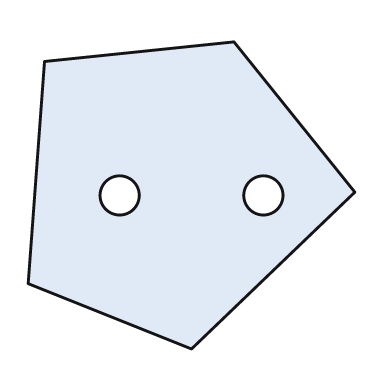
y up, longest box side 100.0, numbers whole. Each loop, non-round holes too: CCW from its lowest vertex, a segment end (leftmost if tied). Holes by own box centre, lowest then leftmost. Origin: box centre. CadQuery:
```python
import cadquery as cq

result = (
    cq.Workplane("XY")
    .moveTo(0.0, -47.0)
    .lineTo(50.0, 1.0)
    .lineTo(13.0, 47.0)
    .lineTo(-45.0, 41.0)
    .lineTo(-50.0, -27.0)
    .close()
    .moveTo(-22.0, 0.0)
    .circle(6.0)
    .moveTo(22.0, 0.0)
    .circle(6.0)
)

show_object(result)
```